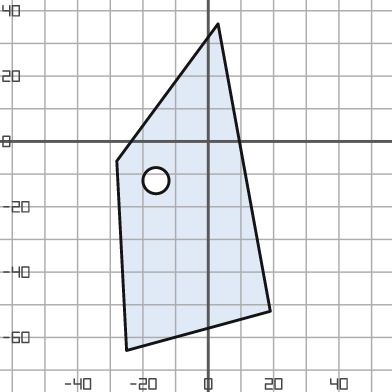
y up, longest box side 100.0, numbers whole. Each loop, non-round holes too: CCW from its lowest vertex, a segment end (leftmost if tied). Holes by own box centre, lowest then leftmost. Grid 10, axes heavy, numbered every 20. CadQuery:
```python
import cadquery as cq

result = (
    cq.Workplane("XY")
    .moveTo(-25.0, -64.0)
    .lineTo(19.0, -52.0)
    .lineTo(3.0, 36.0)
    .lineTo(-28.0, -6.0)
    .close()
    .moveTo(-16.0, -12.0)
    .circle(4.0)
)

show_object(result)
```